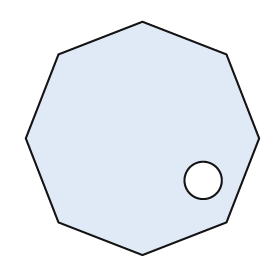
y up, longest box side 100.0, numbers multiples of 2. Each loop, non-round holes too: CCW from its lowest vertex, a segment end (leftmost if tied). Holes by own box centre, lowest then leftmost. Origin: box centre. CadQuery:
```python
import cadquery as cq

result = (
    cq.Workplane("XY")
    .moveTo(0.0, -50.0)
    .lineTo(36.0, -36.0)
    .lineTo(50.0, 0.0)
    .lineTo(36.0, 36.0)
    .lineTo(0.0, 50.0)
    .lineTo(-36.0, 36.0)
    .lineTo(-50.0, 0.0)
    .lineTo(-36.0, -36.0)
    .close()
    .moveTo(26.0, -18.0)
    .circle(8.0)
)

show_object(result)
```